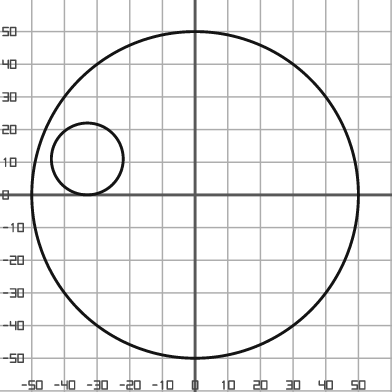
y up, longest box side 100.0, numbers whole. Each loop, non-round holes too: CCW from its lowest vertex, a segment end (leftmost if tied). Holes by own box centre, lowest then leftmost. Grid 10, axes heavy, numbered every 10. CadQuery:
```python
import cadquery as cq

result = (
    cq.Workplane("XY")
    .moveTo(0.0, 0.0)
    .circle(50.0)
    .moveTo(-33.0, 11.0)
    .circle(11.0)
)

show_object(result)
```